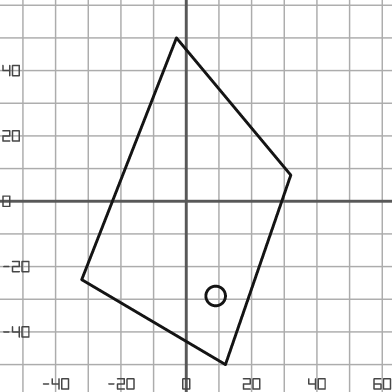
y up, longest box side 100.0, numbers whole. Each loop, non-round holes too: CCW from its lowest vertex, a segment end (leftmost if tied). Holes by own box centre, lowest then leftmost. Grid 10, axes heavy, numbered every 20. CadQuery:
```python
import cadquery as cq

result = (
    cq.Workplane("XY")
    .moveTo(12.0, -50.0)
    .lineTo(32.0, 8.0)
    .lineTo(-3.0, 50.0)
    .lineTo(-32.0, -24.0)
    .close()
    .moveTo(9.0, -29.0)
    .circle(3.0)
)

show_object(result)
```